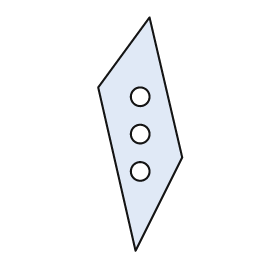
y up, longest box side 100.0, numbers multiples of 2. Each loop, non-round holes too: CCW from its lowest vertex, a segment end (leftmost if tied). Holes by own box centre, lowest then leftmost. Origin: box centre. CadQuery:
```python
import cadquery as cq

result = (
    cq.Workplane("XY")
    .moveTo(-2.0, -50.0)
    .lineTo(18.0, -10.0)
    .lineTo(4.0, 50.0)
    .lineTo(-18.0, 20.0)
    .close()
    .moveTo(0.0, -16.0)
    .circle(4.0)
    .moveTo(0.0, 0.0)
    .circle(4.0)
    .moveTo(0.0, 16.0)
    .circle(4.0)
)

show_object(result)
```